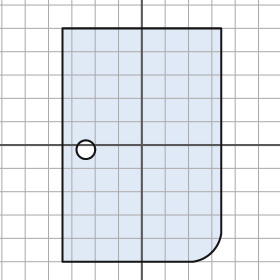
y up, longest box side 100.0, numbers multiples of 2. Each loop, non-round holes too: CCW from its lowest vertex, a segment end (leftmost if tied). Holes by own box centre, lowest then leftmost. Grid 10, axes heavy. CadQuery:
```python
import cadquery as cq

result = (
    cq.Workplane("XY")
    .moveTo(-34.0, -50.0)
    .lineTo(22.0, -50.0)
    .threePointArc((30.0, -46.0), (34.0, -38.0))
    .lineTo(34.0, 50.0)
    .lineTo(-34.0, 50.0)
    .close()
    .moveTo(-24.0, -2.0)
    .circle(4.0)
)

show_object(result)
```